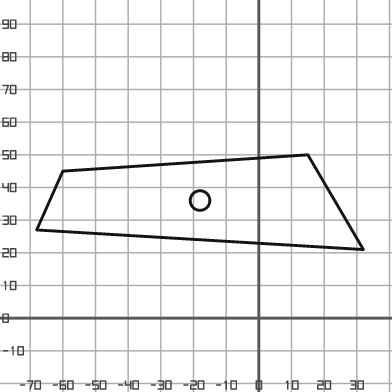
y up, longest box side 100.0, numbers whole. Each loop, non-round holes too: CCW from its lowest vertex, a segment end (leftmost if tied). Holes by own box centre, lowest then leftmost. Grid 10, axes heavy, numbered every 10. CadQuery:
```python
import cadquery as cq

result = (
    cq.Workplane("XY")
    .moveTo(32.0, 21.0)
    .lineTo(15.0, 50.0)
    .lineTo(-60.0, 45.0)
    .lineTo(-68.0, 27.0)
    .close()
    .moveTo(-18.0, 36.0)
    .circle(3.0)
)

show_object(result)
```